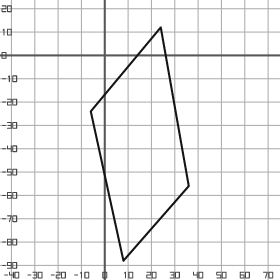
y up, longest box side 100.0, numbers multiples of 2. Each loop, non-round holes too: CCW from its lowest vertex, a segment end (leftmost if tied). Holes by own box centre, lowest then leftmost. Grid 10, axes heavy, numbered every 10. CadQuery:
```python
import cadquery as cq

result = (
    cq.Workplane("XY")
    .moveTo(8.0, -88.0)
    .lineTo(36.0, -56.0)
    .lineTo(24.0, 12.0)
    .lineTo(-6.0, -24.0)
    .close()
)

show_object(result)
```